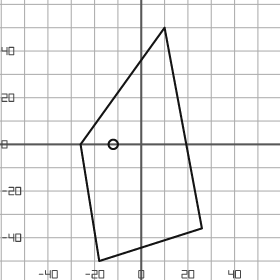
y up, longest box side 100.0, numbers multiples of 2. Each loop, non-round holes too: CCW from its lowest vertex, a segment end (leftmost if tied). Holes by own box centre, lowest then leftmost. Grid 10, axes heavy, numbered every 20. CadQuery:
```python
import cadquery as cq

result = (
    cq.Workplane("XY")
    .moveTo(-18.0, -50.0)
    .lineTo(26.0, -36.0)
    .lineTo(10.0, 50.0)
    .lineTo(-26.0, 0.0)
    .close()
    .moveTo(-12.0, 0.0)
    .circle(2.0)
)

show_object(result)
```